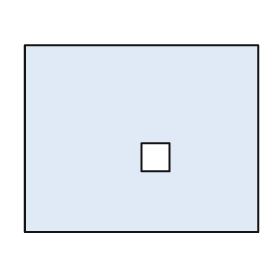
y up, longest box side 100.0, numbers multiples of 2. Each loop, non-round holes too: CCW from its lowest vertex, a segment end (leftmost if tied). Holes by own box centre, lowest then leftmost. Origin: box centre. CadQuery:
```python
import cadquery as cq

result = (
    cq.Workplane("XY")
    .moveTo(-50.0, -40.0)
    .lineTo(50.0, -40.0)
    .lineTo(50.0, 40.0)
    .lineTo(-50.0, 40.0)
    .close()
    .moveTo(0.0, -14.0)
    .lineTo(12.0, -14.0)
    .lineTo(12.0, -2.0)
    .lineTo(0.0, -2.0)
    .close()
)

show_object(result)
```